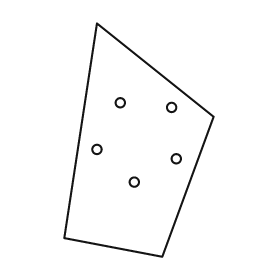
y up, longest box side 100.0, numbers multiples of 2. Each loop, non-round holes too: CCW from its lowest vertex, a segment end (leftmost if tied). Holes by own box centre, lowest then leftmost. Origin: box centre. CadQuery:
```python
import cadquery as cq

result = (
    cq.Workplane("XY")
    .moveTo(10.0, -50.0)
    .lineTo(32.0, 10.0)
    .lineTo(-18.0, 50.0)
    .lineTo(-32.0, -42.0)
    .close()
    .moveTo(-2.0, -18.0)
    .circle(2.0)
    .moveTo(16.0, -8.0)
    .circle(2.0)
    .moveTo(-18.0, -4.0)
    .circle(2.0)
    .moveTo(14.0, 14.0)
    .circle(2.0)
    .moveTo(-8.0, 16.0)
    .circle(2.0)
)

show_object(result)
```